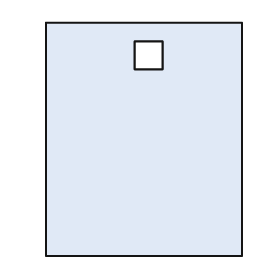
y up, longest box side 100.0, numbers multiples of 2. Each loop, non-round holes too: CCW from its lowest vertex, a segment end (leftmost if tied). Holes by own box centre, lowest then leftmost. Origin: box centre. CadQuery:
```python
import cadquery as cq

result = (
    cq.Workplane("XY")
    .moveTo(-42.0, -50.0)
    .lineTo(42.0, -50.0)
    .lineTo(42.0, 50.0)
    .lineTo(-42.0, 50.0)
    .close()
    .moveTo(-4.0, 30.0)
    .lineTo(8.0, 30.0)
    .lineTo(8.0, 42.0)
    .lineTo(-4.0, 42.0)
    .close()
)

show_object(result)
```